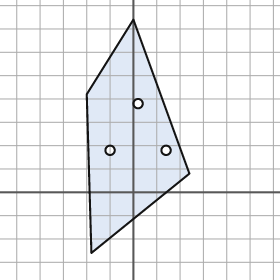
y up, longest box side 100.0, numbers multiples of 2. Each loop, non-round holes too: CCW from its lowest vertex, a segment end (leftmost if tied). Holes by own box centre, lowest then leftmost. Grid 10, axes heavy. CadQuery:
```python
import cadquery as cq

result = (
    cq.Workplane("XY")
    .moveTo(-18.0, -26.0)
    .lineTo(24.0, 8.0)
    .lineTo(0.0, 74.0)
    .lineTo(-20.0, 42.0)
    .close()
    .moveTo(-10.0, 18.0)
    .circle(2.0)
    .moveTo(14.0, 18.0)
    .circle(2.0)
    .moveTo(2.0, 38.0)
    .circle(2.0)
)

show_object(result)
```